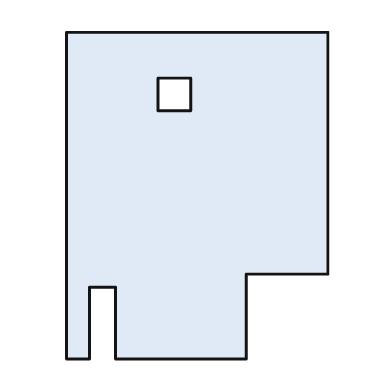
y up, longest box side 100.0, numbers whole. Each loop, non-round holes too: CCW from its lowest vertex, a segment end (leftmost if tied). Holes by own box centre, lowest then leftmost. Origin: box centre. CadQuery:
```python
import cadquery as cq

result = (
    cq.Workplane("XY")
    .moveTo(-40.0, -50.0)
    .lineTo(-33.0, -50.0)
    .lineTo(-33.0, -28.0)
    .lineTo(-25.0, -28.0)
    .lineTo(-25.0, -50.0)
    .lineTo(15.0, -50.0)
    .lineTo(15.0, -24.0)
    .lineTo(40.0, -24.0)
    .lineTo(40.0, 50.0)
    .lineTo(-40.0, 50.0)
    .close()
    .moveTo(-12.0, 26.0)
    .lineTo(-2.0, 26.0)
    .lineTo(-2.0, 36.0)
    .lineTo(-12.0, 36.0)
    .close()
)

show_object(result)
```